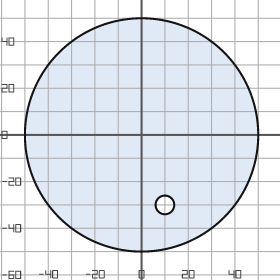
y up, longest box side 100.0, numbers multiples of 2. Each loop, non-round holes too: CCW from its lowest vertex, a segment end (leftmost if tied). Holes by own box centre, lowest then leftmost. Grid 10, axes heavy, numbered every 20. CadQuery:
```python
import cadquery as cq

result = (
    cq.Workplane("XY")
    .moveTo(0.0, 0.0)
    .circle(50.0)
    .moveTo(10.0, -30.0)
    .circle(4.0)
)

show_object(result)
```